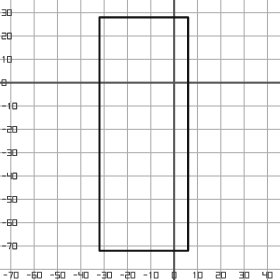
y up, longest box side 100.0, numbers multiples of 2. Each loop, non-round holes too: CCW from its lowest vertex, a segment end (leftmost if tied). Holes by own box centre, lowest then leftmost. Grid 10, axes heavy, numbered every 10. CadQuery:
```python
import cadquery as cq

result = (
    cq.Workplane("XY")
    .moveTo(-32.0, -72.0)
    .lineTo(6.0, -72.0)
    .lineTo(6.0, 28.0)
    .lineTo(-32.0, 28.0)
    .close()
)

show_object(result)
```